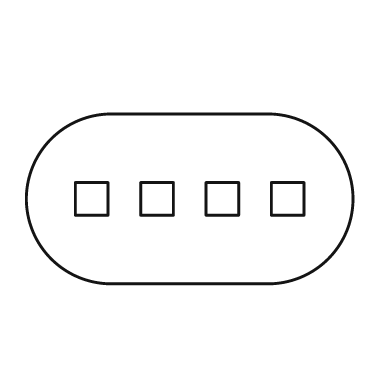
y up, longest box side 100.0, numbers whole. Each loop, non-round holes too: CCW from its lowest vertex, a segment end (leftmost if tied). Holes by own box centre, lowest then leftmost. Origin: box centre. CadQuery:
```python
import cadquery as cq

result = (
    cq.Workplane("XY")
    .moveTo(-24.0, -26.0)
    .lineTo(24.0, -26.0)
    .threePointArc((50.0, 0.0), (24.0, 26.0))
    .lineTo(-24.0, 26.0)
    .threePointArc((-50.0, 0.0), (-24.0, -26.0))
    .close()
    .moveTo(-35.0, -5.0)
    .lineTo(-25.0, -5.0)
    .lineTo(-25.0, 5.0)
    .lineTo(-35.0, 5.0)
    .close()
    .moveTo(-15.0, -5.0)
    .lineTo(-5.0, -5.0)
    .lineTo(-5.0, 5.0)
    .lineTo(-15.0, 5.0)
    .close()
    .moveTo(5.0, -5.0)
    .lineTo(15.0, -5.0)
    .lineTo(15.0, 5.0)
    .lineTo(5.0, 5.0)
    .close()
    .moveTo(25.0, -5.0)
    .lineTo(35.0, -5.0)
    .lineTo(35.0, 5.0)
    .lineTo(25.0, 5.0)
    .close()
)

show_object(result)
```